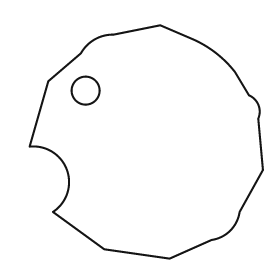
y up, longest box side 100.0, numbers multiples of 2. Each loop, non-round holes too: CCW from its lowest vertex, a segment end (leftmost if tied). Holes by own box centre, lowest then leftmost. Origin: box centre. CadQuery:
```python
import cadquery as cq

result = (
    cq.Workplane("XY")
    .moveTo(10.0, -50.0)
    .lineTo(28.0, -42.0)
    .threePointArc((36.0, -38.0), (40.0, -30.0))
    .lineTo(50.0, -12.0)
    .lineTo(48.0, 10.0)
    .threePointArc((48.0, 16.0), (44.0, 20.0))
    .lineTo(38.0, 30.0)
    .threePointArc((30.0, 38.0), (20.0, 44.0))
    .lineTo(6.0, 50.0)
    .lineTo(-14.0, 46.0)
    .threePointArc((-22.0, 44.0), (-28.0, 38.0))
    .lineTo(-42.0, 26.0)
    .lineTo(-50.0, -2.0)
    .threePointArc((-34.0, -12.0), (-40.0, -30.0))
    .lineTo(-18.0, -46.0)
    .close()
    .moveTo(-26.0, 22.0)
    .circle(6.0)
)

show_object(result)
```